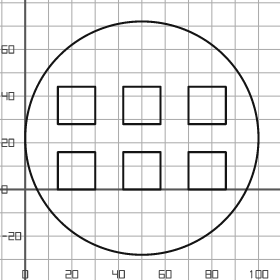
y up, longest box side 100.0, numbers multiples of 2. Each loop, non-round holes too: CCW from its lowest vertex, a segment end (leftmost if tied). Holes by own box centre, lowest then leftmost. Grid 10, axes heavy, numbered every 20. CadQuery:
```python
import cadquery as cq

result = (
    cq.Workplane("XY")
    .moveTo(50.0, 22.0)
    .circle(50.0)
    .moveTo(14.0, 0.0)
    .lineTo(30.0, 0.0)
    .lineTo(30.0, 16.0)
    .lineTo(14.0, 16.0)
    .close()
    .moveTo(42.0, 0.0)
    .lineTo(58.0, 0.0)
    .lineTo(58.0, 16.0)
    .lineTo(42.0, 16.0)
    .close()
    .moveTo(70.0, 0.0)
    .lineTo(86.0, 0.0)
    .lineTo(86.0, 16.0)
    .lineTo(70.0, 16.0)
    .close()
    .moveTo(14.0, 28.0)
    .lineTo(30.0, 28.0)
    .lineTo(30.0, 44.0)
    .lineTo(14.0, 44.0)
    .close()
    .moveTo(42.0, 28.0)
    .lineTo(58.0, 28.0)
    .lineTo(58.0, 44.0)
    .lineTo(42.0, 44.0)
    .close()
    .moveTo(70.0, 28.0)
    .lineTo(86.0, 28.0)
    .lineTo(86.0, 44.0)
    .lineTo(70.0, 44.0)
    .close()
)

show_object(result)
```